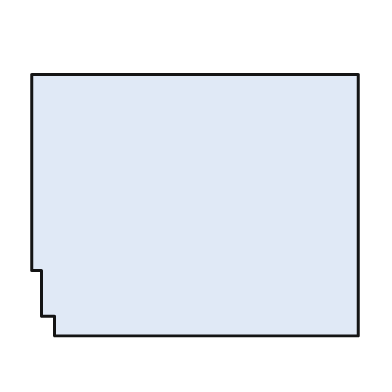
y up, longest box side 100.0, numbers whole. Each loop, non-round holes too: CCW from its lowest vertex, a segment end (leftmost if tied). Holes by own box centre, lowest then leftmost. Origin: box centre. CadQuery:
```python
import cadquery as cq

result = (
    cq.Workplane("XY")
    .moveTo(-43.0, -40.0)
    .lineTo(50.0, -40.0)
    .lineTo(50.0, 40.0)
    .lineTo(-50.0, 40.0)
    .lineTo(-50.0, -20.0)
    .lineTo(-47.0, -20.0)
    .lineTo(-47.0, -34.0)
    .lineTo(-43.0, -34.0)
    .close()
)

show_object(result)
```